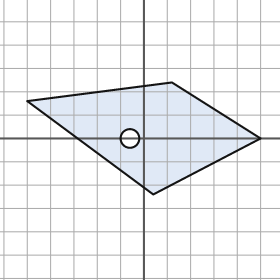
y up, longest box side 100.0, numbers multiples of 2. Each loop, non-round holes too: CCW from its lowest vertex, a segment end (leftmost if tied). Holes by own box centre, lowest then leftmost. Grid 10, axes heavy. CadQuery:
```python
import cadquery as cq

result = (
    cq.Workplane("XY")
    .moveTo(4.0, -24.0)
    .lineTo(50.0, 0.0)
    .lineTo(12.0, 24.0)
    .lineTo(-50.0, 16.0)
    .close()
    .moveTo(-6.0, 0.0)
    .circle(4.0)
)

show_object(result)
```